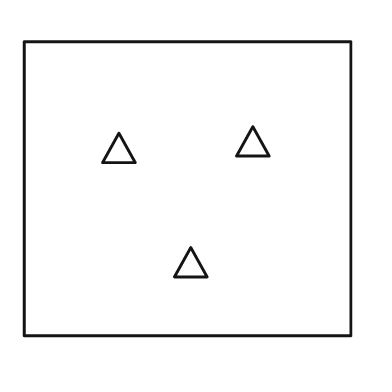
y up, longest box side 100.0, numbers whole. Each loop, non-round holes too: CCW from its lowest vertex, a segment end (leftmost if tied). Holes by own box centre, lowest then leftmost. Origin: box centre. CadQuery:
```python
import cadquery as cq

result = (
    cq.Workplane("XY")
    .moveTo(-50.0, -45.0)
    .lineTo(50.0, -45.0)
    .lineTo(50.0, 45.0)
    .lineTo(-50.0, 45.0)
    .close()
    .moveTo(-4.0, -27.0)
    .lineTo(6.0, -27.0)
    .lineTo(1.0, -18.0)
    .close()
    .moveTo(-26.0, 8.0)
    .lineTo(-16.0, 8.0)
    .lineTo(-21.0, 17.0)
    .close()
    .moveTo(15.0, 10.0)
    .lineTo(25.0, 10.0)
    .lineTo(20.0, 19.0)
    .close()
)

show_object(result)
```